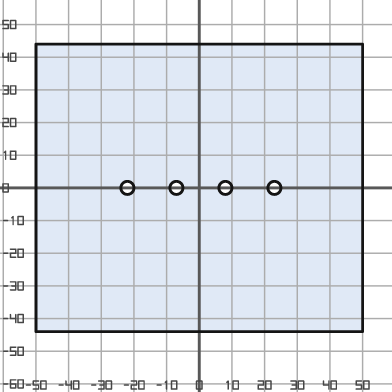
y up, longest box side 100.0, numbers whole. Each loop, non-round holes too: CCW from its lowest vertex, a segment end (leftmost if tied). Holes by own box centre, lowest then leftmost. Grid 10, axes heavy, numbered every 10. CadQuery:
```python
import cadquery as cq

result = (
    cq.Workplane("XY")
    .moveTo(-50.0, -44.0)
    .lineTo(50.0, -44.0)
    .lineTo(50.0, 44.0)
    .lineTo(-50.0, 44.0)
    .close()
    .moveTo(-22.0, 0.0)
    .circle(2.0)
    .moveTo(-7.0, 0.0)
    .circle(2.0)
    .moveTo(8.0, 0.0)
    .circle(2.0)
    .moveTo(23.0, 0.0)
    .circle(2.0)
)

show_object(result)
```